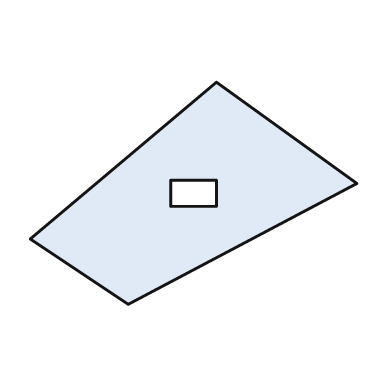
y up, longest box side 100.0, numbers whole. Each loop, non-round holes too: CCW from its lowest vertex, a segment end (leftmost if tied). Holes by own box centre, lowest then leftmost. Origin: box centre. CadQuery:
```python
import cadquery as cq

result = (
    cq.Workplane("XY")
    .moveTo(-20.0, -34.0)
    .lineTo(50.0, 3.0)
    .lineTo(7.0, 34.0)
    .lineTo(-50.0, -14.0)
    .close()
    .moveTo(-7.0, -4.0)
    .lineTo(7.0, -4.0)
    .lineTo(7.0, 4.0)
    .lineTo(-7.0, 4.0)
    .close()
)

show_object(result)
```